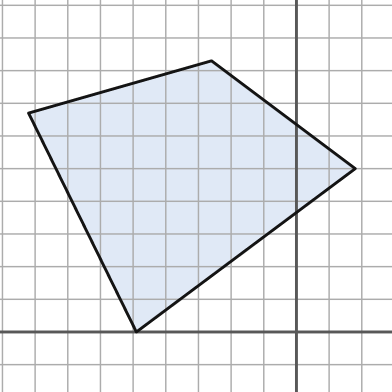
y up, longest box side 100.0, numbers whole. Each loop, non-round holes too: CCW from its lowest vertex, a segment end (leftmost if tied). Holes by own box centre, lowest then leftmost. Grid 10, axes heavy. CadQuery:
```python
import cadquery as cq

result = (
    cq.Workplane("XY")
    .moveTo(-49.0, 0.0)
    .lineTo(18.0, 50.0)
    .lineTo(-26.0, 83.0)
    .lineTo(-82.0, 67.0)
    .close()
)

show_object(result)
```